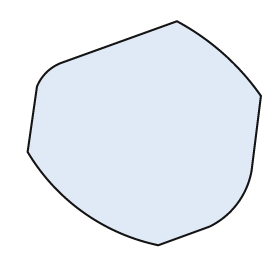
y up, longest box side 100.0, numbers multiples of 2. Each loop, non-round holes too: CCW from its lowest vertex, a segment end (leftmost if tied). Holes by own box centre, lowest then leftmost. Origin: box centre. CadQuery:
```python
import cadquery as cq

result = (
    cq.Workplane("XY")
    .moveTo(6.0, -48.0)
    .lineTo(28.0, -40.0)
    .threePointArc((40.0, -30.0), (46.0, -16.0))
    .lineTo(50.0, 16.0)
    .threePointArc((34.0, 34.0), (14.0, 48.0))
    .lineTo(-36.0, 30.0)
    .threePointArc((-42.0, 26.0), (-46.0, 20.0))
    .lineTo(-50.0, -8.0)
    .threePointArc((-26.0, -34.0), (6.0, -48.0))
    .close()
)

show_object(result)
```